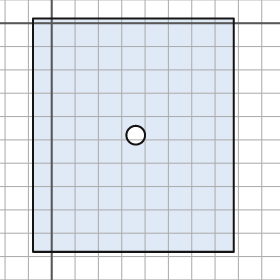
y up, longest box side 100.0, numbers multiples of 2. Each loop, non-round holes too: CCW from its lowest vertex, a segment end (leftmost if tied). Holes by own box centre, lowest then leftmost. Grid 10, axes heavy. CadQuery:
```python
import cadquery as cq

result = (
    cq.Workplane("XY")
    .moveTo(-8.0, -98.0)
    .lineTo(78.0, -98.0)
    .lineTo(78.0, 2.0)
    .lineTo(-8.0, 2.0)
    .close()
    .moveTo(36.0, -48.0)
    .circle(4.0)
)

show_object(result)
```